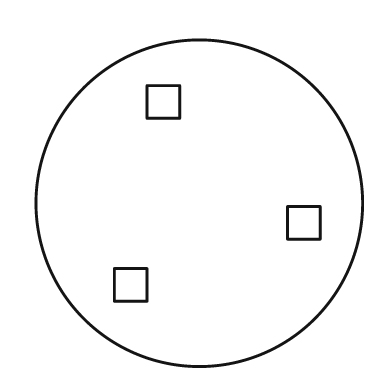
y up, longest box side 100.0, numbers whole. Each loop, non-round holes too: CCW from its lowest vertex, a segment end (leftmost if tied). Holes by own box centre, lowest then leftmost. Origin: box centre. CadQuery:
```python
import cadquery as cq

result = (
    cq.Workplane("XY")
    .moveTo(0.0, 0.0)
    .circle(50.0)
    .moveTo(-26.0, -30.0)
    .lineTo(-16.0, -30.0)
    .lineTo(-16.0, -20.0)
    .lineTo(-26.0, -20.0)
    .close()
    .moveTo(27.0, -11.0)
    .lineTo(37.0, -11.0)
    .lineTo(37.0, -1.0)
    .lineTo(27.0, -1.0)
    .close()
    .moveTo(-16.0, 26.0)
    .lineTo(-6.0, 26.0)
    .lineTo(-6.0, 36.0)
    .lineTo(-16.0, 36.0)
    .close()
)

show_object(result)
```